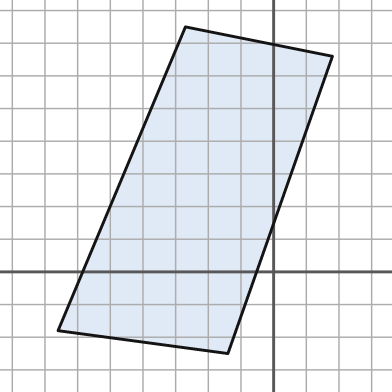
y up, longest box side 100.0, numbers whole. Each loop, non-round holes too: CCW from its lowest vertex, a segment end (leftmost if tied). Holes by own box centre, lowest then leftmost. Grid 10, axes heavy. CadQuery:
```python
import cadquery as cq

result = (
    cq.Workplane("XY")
    .moveTo(-14.0, -25.0)
    .lineTo(18.0, 66.0)
    .lineTo(-27.0, 75.0)
    .lineTo(-66.0, -18.0)
    .close()
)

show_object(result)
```